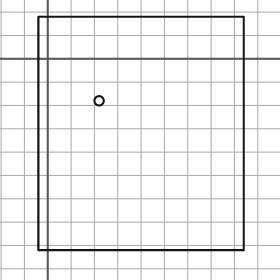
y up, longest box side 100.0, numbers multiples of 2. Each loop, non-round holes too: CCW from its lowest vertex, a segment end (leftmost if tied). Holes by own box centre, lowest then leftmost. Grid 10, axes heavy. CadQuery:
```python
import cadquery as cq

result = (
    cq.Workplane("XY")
    .moveTo(-4.0, -82.0)
    .lineTo(84.0, -82.0)
    .lineTo(84.0, 18.0)
    .lineTo(-4.0, 18.0)
    .close()
    .moveTo(22.0, -18.0)
    .circle(2.0)
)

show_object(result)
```